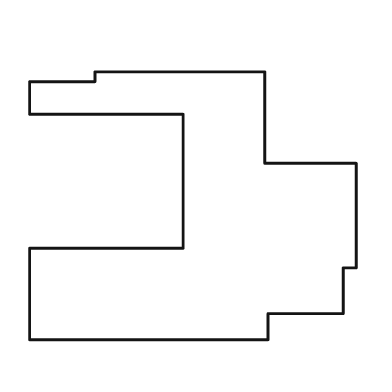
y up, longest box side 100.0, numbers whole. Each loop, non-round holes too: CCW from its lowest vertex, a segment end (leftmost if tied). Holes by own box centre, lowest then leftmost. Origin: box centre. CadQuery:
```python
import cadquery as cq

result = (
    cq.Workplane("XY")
    .moveTo(-50.0, -41.0)
    .lineTo(23.0, -41.0)
    .lineTo(23.0, -33.0)
    .lineTo(46.0, -33.0)
    .lineTo(46.0, -19.0)
    .lineTo(50.0, -19.0)
    .lineTo(50.0, 13.0)
    .lineTo(22.0, 13.0)
    .lineTo(22.0, 41.0)
    .lineTo(-30.0, 41.0)
    .lineTo(-30.0, 38.0)
    .lineTo(-50.0, 38.0)
    .lineTo(-50.0, 28.0)
    .lineTo(-3.0, 28.0)
    .lineTo(-3.0, -13.0)
    .lineTo(-50.0, -13.0)
    .close()
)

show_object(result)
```